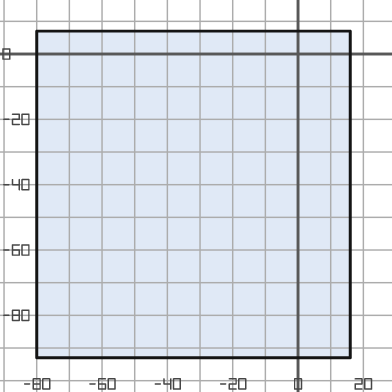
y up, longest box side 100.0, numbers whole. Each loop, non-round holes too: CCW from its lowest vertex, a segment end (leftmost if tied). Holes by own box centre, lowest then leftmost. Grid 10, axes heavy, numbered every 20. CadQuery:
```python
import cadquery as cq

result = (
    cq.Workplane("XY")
    .moveTo(-80.0, -93.0)
    .lineTo(16.0, -93.0)
    .lineTo(16.0, 7.0)
    .lineTo(-80.0, 7.0)
    .close()
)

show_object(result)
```